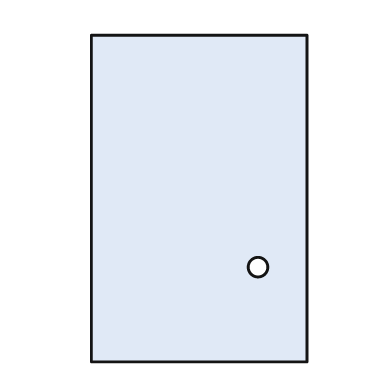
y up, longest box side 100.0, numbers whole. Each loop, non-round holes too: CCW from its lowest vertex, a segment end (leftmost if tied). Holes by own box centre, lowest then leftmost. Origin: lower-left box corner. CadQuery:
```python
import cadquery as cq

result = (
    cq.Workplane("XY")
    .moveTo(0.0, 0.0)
    .lineTo(66.0, 0.0)
    .lineTo(66.0, 100.0)
    .lineTo(0.0, 100.0)
    .close()
    .moveTo(51.0, 29.0)
    .circle(3.0)
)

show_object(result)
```